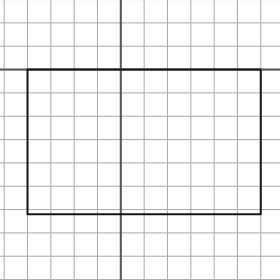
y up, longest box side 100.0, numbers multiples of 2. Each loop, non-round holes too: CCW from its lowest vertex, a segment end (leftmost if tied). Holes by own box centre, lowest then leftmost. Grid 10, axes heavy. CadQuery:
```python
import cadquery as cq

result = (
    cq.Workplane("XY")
    .moveTo(-40.0, -62.0)
    .lineTo(60.0, -62.0)
    .lineTo(60.0, 0.0)
    .lineTo(-40.0, 0.0)
    .close()
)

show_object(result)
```